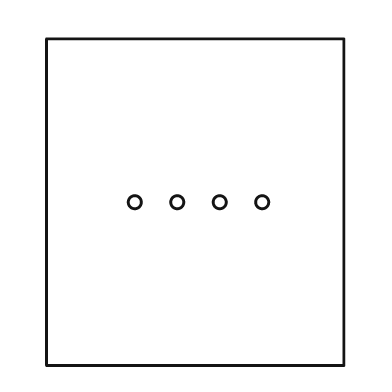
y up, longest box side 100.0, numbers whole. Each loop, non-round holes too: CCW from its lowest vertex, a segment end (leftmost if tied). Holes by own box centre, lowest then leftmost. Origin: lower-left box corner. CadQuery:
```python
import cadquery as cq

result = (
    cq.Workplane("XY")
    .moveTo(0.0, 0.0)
    .lineTo(91.0, 0.0)
    .lineTo(91.0, 100.0)
    .lineTo(0.0, 100.0)
    .close()
    .moveTo(27.0, 50.0)
    .circle(2.0)
    .moveTo(40.0, 50.0)
    .circle(2.0)
    .moveTo(53.0, 50.0)
    .circle(2.0)
    .moveTo(66.0, 50.0)
    .circle(2.0)
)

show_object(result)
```